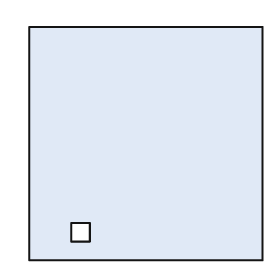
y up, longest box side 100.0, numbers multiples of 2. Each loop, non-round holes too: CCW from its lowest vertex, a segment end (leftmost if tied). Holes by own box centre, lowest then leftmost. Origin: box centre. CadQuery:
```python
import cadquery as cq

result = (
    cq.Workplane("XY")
    .moveTo(-50.0, -50.0)
    .lineTo(50.0, -50.0)
    .lineTo(50.0, 50.0)
    .lineTo(-50.0, 50.0)
    .close()
    .moveTo(-32.0, -42.0)
    .lineTo(-24.0, -42.0)
    .lineTo(-24.0, -34.0)
    .lineTo(-32.0, -34.0)
    .close()
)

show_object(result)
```